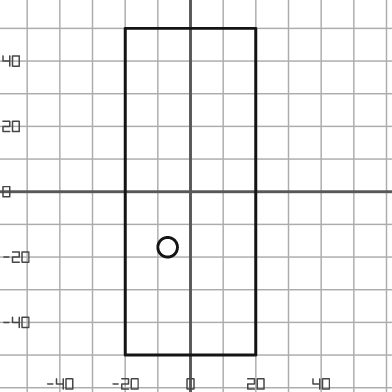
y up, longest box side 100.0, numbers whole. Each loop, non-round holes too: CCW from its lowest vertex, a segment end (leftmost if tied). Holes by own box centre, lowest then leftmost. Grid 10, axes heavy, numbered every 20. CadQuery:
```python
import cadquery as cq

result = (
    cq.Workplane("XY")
    .moveTo(-20.0, -50.0)
    .lineTo(20.0, -50.0)
    .lineTo(20.0, 50.0)
    .lineTo(-20.0, 50.0)
    .close()
    .moveTo(-7.0, -17.0)
    .circle(3.0)
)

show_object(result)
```